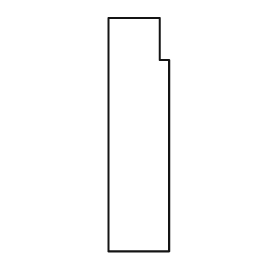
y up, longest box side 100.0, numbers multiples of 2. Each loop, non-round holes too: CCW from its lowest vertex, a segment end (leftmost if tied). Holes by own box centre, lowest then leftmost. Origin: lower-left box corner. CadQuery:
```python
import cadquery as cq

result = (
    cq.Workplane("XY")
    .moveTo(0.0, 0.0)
    .lineTo(26.0, 0.0)
    .lineTo(26.0, 82.0)
    .lineTo(22.0, 82.0)
    .lineTo(22.0, 100.0)
    .lineTo(0.0, 100.0)
    .close()
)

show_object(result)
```